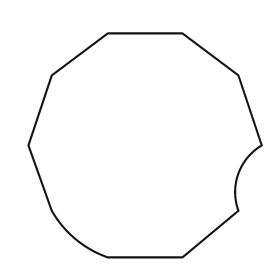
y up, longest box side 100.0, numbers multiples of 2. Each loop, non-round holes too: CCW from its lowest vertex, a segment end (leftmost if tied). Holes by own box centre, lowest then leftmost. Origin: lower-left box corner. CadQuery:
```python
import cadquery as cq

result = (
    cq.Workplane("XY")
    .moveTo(34.0, 0.0)
    .lineTo(66.0, 0.0)
    .lineTo(90.0, 20.0)
    .threePointArc((90.0, 36.0), (100.0, 48.0))
    .lineTo(90.0, 78.0)
    .lineTo(66.0, 96.0)
    .lineTo(34.0, 96.0)
    .lineTo(10.0, 78.0)
    .lineTo(0.0, 48.0)
    .lineTo(10.0, 20.0)
    .threePointArc((20.0, 8.0), (34.0, 0.0))
    .close()
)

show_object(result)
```